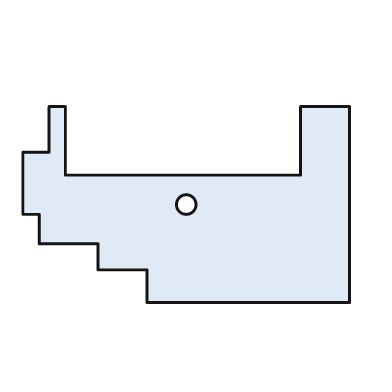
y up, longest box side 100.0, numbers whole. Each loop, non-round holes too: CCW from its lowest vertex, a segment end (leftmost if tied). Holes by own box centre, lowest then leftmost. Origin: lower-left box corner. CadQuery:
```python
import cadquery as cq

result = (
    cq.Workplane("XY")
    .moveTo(38.0, 0.0)
    .lineTo(100.0, 0.0)
    .lineTo(100.0, 60.0)
    .lineTo(85.0, 60.0)
    .lineTo(85.0, 39.0)
    .lineTo(13.0, 39.0)
    .lineTo(13.0, 60.0)
    .lineTo(8.0, 60.0)
    .lineTo(8.0, 46.0)
    .lineTo(0.0, 46.0)
    .lineTo(0.0, 27.0)
    .lineTo(5.0, 27.0)
    .lineTo(5.0, 18.0)
    .lineTo(23.0, 18.0)
    .lineTo(23.0, 10.0)
    .lineTo(38.0, 10.0)
    .close()
    .moveTo(50.0, 30.0)
    .circle(3.0)
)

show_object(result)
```